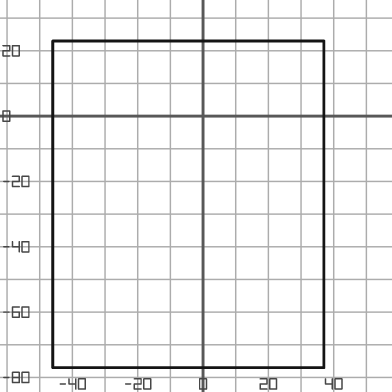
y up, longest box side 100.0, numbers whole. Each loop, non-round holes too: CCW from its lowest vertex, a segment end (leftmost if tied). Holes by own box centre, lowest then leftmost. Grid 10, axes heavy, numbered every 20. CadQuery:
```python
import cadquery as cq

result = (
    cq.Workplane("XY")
    .moveTo(-46.0, -77.0)
    .lineTo(37.0, -77.0)
    .lineTo(37.0, 23.0)
    .lineTo(-46.0, 23.0)
    .close()
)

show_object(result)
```